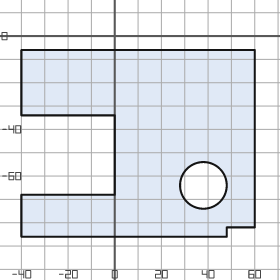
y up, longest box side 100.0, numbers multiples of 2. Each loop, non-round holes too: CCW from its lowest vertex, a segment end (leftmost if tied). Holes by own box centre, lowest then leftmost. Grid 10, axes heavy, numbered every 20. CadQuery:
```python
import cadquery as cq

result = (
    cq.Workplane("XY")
    .moveTo(-40.0, -86.0)
    .lineTo(48.0, -86.0)
    .lineTo(48.0, -82.0)
    .lineTo(60.0, -82.0)
    .lineTo(60.0, -6.0)
    .lineTo(-40.0, -6.0)
    .lineTo(-40.0, -34.0)
    .lineTo(0.0, -34.0)
    .lineTo(0.0, -68.0)
    .lineTo(-40.0, -68.0)
    .close()
    .moveTo(38.0, -64.0)
    .circle(10.0)
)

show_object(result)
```